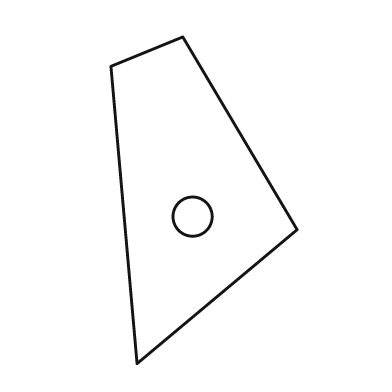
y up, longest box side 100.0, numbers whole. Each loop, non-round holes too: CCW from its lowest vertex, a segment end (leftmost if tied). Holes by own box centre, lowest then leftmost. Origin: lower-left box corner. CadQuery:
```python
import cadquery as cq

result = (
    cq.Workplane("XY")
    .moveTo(8.0, 0.0)
    .lineTo(57.0, 41.0)
    .lineTo(22.0, 100.0)
    .lineTo(0.0, 91.0)
    .close()
    .moveTo(25.0, 45.0)
    .circle(6.0)
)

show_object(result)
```